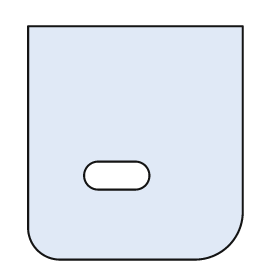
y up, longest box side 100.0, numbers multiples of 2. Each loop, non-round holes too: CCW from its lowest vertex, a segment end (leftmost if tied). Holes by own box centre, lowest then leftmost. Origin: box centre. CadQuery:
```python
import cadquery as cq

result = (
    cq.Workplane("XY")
    .moveTo(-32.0, -50.0)
    .lineTo(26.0, -50.0)
    .threePointArc((40.0, -44.0), (46.0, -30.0))
    .lineTo(46.0, 50.0)
    .lineTo(-46.0, 50.0)
    .lineTo(-46.0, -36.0)
    .threePointArc((-42.0, -46.0), (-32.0, -50.0))
    .close()
    .moveTo(-16.0, -20.0)
    .lineTo(0.0, -20.0)
    .threePointArc((6.0, -14.0), (0.0, -8.0))
    .lineTo(-16.0, -8.0)
    .threePointArc((-22.0, -14.0), (-16.0, -20.0))
    .close()
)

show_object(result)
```